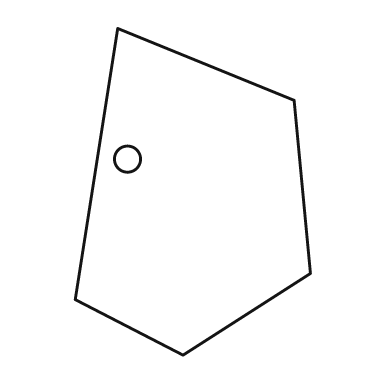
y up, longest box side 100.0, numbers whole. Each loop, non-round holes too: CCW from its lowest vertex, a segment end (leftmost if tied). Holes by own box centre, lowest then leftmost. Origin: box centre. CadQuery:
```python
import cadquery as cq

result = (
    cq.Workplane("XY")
    .moveTo(-3.0, -50.0)
    .lineTo(36.0, -25.0)
    .lineTo(31.0, 28.0)
    .lineTo(-23.0, 50.0)
    .lineTo(-36.0, -33.0)
    .close()
    .moveTo(-20.0, 10.0)
    .circle(4.0)
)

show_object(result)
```